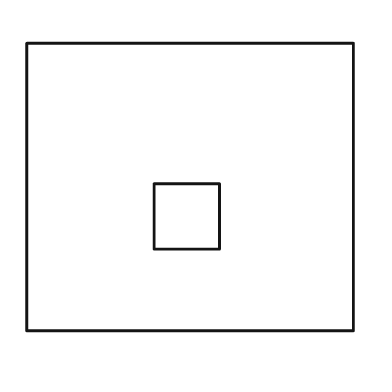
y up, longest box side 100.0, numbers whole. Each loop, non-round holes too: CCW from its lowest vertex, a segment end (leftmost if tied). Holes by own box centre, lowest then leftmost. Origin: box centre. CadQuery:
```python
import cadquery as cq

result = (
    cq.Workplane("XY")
    .moveTo(-50.0, -44.0)
    .lineTo(50.0, -44.0)
    .lineTo(50.0, 44.0)
    .lineTo(-50.0, 44.0)
    .close()
    .moveTo(-11.0, -19.0)
    .lineTo(9.0, -19.0)
    .lineTo(9.0, 1.0)
    .lineTo(-11.0, 1.0)
    .close()
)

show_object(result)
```